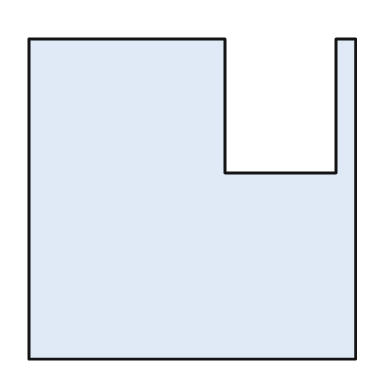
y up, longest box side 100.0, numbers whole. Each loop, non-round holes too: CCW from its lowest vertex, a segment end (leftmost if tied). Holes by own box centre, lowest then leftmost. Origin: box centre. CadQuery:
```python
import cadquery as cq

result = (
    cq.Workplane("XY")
    .moveTo(-50.0, -49.0)
    .lineTo(50.0, -49.0)
    .lineTo(50.0, 49.0)
    .lineTo(44.0, 49.0)
    .lineTo(44.0, 8.0)
    .lineTo(10.0, 8.0)
    .lineTo(10.0, 49.0)
    .lineTo(-50.0, 49.0)
    .close()
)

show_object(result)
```